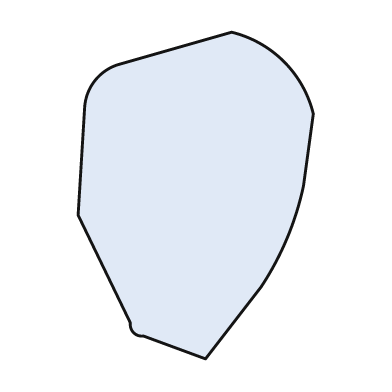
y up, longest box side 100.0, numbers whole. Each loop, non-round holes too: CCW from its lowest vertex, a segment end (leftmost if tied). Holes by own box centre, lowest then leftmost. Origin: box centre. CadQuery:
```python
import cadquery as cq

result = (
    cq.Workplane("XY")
    .moveTo(3.0, -50.0)
    .lineTo(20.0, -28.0)
    .threePointArc((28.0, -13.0), (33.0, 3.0))
    .lineTo(36.0, 25.0)
    .threePointArc((27.0, 41.0), (11.0, 50.0))
    .lineTo(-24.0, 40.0)
    .threePointArc((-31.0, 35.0), (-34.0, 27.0))
    .lineTo(-36.0, -6.0)
    .lineTo(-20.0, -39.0)
    .threePointArc((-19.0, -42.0), (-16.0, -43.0))
    .close()
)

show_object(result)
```